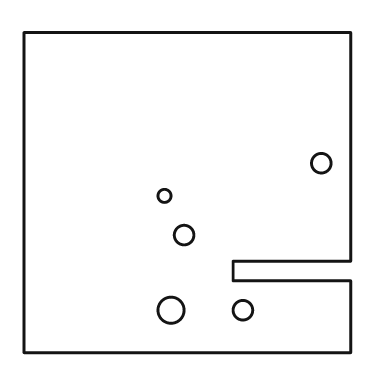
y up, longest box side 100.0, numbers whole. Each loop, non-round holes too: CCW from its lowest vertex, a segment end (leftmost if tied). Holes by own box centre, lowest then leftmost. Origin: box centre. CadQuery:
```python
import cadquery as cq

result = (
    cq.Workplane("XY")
    .moveTo(-50.0, -49.0)
    .lineTo(50.0, -49.0)
    .lineTo(50.0, -27.0)
    .lineTo(14.0, -27.0)
    .lineTo(14.0, -21.0)
    .lineTo(50.0, -21.0)
    .lineTo(50.0, 49.0)
    .lineTo(-50.0, 49.0)
    .close()
    .moveTo(-5.0, -36.0)
    .circle(4.0)
    .moveTo(17.0, -36.0)
    .circle(3.0)
    .moveTo(-1.0, -13.0)
    .circle(3.0)
    .moveTo(-7.0, -1.0)
    .circle(2.0)
    .moveTo(41.0, 9.0)
    .circle(3.0)
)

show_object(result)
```